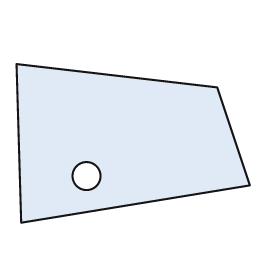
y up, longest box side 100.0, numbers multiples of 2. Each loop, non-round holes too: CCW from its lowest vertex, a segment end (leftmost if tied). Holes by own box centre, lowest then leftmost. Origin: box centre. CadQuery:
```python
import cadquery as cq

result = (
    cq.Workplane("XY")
    .moveTo(-48.0, -34.0)
    .lineTo(50.0, -18.0)
    .lineTo(36.0, 24.0)
    .lineTo(-50.0, 34.0)
    .close()
    .moveTo(-20.0, -14.0)
    .circle(6.0)
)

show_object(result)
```